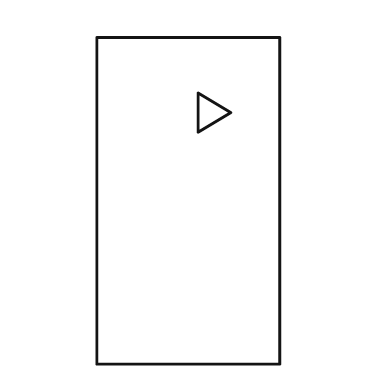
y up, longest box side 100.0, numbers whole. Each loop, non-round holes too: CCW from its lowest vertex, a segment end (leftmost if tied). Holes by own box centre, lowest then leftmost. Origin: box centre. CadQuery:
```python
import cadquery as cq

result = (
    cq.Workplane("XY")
    .moveTo(-28.0, -50.0)
    .lineTo(28.0, -50.0)
    .lineTo(28.0, 50.0)
    .lineTo(-28.0, 50.0)
    .close()
    .moveTo(3.0, 21.0)
    .lineTo(13.0, 27.0)
    .lineTo(3.0, 33.0)
    .close()
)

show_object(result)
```